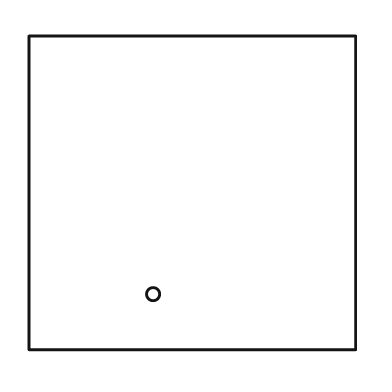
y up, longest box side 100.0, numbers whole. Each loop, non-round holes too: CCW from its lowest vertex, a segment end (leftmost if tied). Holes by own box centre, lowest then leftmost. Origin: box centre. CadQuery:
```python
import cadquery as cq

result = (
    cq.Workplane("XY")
    .moveTo(-50.0, -48.0)
    .lineTo(50.0, -48.0)
    .lineTo(50.0, 48.0)
    .lineTo(-50.0, 48.0)
    .close()
    .moveTo(-12.0, -31.0)
    .circle(2.0)
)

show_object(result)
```